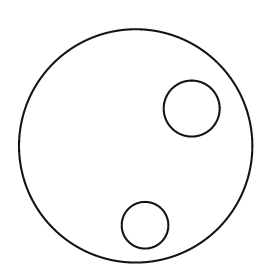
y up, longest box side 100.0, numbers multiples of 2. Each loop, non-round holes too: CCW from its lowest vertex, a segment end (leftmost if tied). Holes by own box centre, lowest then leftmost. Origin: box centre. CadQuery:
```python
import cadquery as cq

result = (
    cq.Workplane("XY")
    .moveTo(0.0, 0.0)
    .circle(50.0)
    .moveTo(4.0, -34.0)
    .circle(10.0)
    .moveTo(24.0, 16.0)
    .circle(12.0)
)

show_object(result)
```